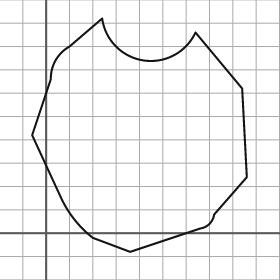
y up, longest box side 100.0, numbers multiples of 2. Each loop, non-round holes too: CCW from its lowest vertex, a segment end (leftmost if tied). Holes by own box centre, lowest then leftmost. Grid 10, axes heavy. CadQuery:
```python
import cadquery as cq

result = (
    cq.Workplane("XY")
    .moveTo(36.0, -8.0)
    .lineTo(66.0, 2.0)
    .threePointArc((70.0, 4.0), (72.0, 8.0))
    .lineTo(86.0, 24.0)
    .lineTo(84.0, 62.0)
    .lineTo(64.0, 86.0)
    .threePointArc((42.0, 74.0), (24.0, 92.0))
    .lineTo(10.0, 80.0)
    .threePointArc((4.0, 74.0), (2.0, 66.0))
    .lineTo(-6.0, 42.0)
    .lineTo(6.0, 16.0)
    .threePointArc((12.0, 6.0), (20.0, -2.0))
    .close()
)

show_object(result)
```